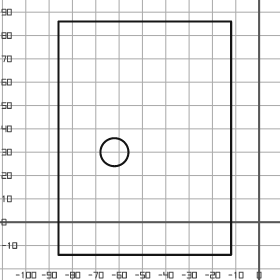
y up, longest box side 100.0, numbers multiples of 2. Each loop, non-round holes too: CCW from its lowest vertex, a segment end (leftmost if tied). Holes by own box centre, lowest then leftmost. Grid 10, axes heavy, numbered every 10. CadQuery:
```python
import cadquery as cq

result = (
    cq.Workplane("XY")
    .moveTo(-86.0, -14.0)
    .lineTo(-12.0, -14.0)
    .lineTo(-12.0, 86.0)
    .lineTo(-86.0, 86.0)
    .close()
    .moveTo(-62.0, 30.0)
    .circle(6.0)
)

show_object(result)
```